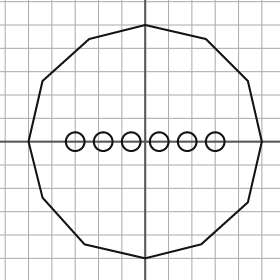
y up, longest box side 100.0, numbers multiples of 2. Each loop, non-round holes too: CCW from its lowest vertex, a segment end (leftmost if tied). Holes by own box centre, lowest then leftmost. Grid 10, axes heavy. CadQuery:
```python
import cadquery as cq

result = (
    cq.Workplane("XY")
    .moveTo(0.0, -50.0)
    .lineTo(24.0, -44.0)
    .lineTo(44.0, -26.0)
    .lineTo(50.0, 0.0)
    .lineTo(44.0, 26.0)
    .lineTo(26.0, 44.0)
    .lineTo(0.0, 50.0)
    .lineTo(-24.0, 44.0)
    .lineTo(-44.0, 26.0)
    .lineTo(-50.0, 0.0)
    .lineTo(-44.0, -24.0)
    .lineTo(-26.0, -44.0)
    .close()
    .moveTo(-30.0, 0.0)
    .circle(4.0)
    .moveTo(-18.0, 0.0)
    .circle(4.0)
    .moveTo(-6.0, 0.0)
    .circle(4.0)
    .moveTo(6.0, 0.0)
    .circle(4.0)
    .moveTo(18.0, 0.0)
    .circle(4.0)
    .moveTo(30.0, 0.0)
    .circle(4.0)
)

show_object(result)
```